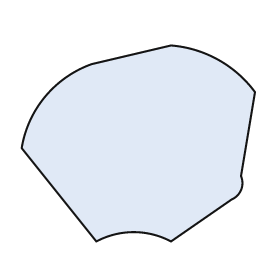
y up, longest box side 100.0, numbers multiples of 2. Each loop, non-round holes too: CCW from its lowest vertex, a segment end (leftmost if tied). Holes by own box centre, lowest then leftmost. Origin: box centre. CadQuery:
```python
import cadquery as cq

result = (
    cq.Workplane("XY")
    .moveTo(-18.0, -42.0)
    .threePointArc((-2.0, -38.0), (14.0, -42.0))
    .lineTo(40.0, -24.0)
    .threePointArc((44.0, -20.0), (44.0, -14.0))
    .lineTo(50.0, 22.0)
    .threePointArc((34.0, 36.0), (14.0, 42.0))
    .lineTo(-20.0, 34.0)
    .threePointArc((-40.0, 20.0), (-50.0, -2.0))
    .close()
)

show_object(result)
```